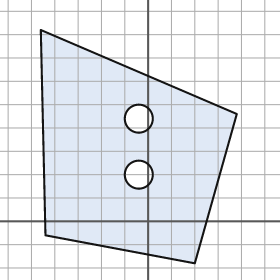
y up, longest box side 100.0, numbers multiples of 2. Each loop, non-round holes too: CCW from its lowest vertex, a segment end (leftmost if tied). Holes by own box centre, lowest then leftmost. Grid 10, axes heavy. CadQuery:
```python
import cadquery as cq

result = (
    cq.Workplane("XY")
    .moveTo(20.0, -18.0)
    .lineTo(38.0, 46.0)
    .lineTo(-46.0, 82.0)
    .lineTo(-44.0, -6.0)
    .close()
    .moveTo(-4.0, 20.0)
    .circle(6.0)
    .moveTo(-4.0, 44.0)
    .circle(6.0)
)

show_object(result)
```